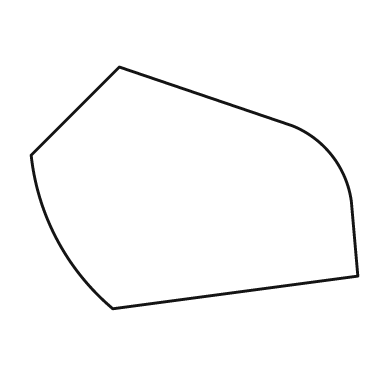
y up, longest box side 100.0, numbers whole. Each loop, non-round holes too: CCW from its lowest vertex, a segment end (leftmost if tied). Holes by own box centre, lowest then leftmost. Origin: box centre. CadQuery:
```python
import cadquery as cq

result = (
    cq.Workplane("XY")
    .moveTo(-25.0, -37.0)
    .lineTo(50.0, -27.0)
    .lineTo(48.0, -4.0)
    .threePointArc((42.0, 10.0), (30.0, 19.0))
    .lineTo(-23.0, 37.0)
    .lineTo(-50.0, 10.0)
    .threePointArc((-42.0, -16.0), (-25.0, -37.0))
    .close()
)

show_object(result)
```